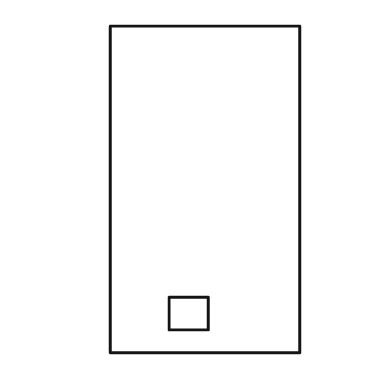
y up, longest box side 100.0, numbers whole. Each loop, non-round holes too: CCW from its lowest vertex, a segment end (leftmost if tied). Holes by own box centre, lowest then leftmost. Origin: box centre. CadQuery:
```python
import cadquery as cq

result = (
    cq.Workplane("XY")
    .moveTo(-29.0, -50.0)
    .lineTo(29.0, -50.0)
    .lineTo(29.0, 50.0)
    .lineTo(-29.0, 50.0)
    .close()
    .moveTo(-11.0, -43.0)
    .lineTo(1.0, -43.0)
    .lineTo(1.0, -33.0)
    .lineTo(-11.0, -33.0)
    .close()
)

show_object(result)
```